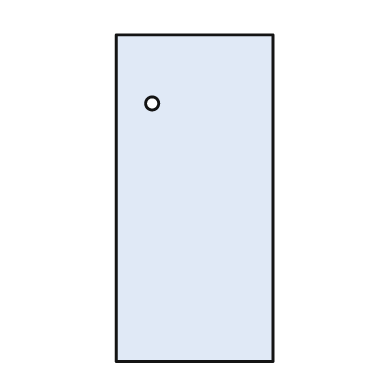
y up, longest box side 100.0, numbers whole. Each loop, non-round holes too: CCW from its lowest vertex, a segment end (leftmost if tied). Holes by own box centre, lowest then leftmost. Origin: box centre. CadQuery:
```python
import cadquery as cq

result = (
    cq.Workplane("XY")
    .moveTo(-24.0, -50.0)
    .lineTo(24.0, -50.0)
    .lineTo(24.0, 50.0)
    .lineTo(-24.0, 50.0)
    .close()
    .moveTo(-13.0, 29.0)
    .circle(2.0)
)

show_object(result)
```